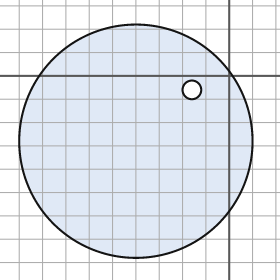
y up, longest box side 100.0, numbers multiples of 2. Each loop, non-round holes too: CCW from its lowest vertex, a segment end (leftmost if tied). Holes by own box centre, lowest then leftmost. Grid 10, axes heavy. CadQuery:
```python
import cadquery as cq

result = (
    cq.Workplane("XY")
    .moveTo(-40.0, -28.0)
    .circle(50.0)
    .moveTo(-16.0, -6.0)
    .circle(4.0)
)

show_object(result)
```